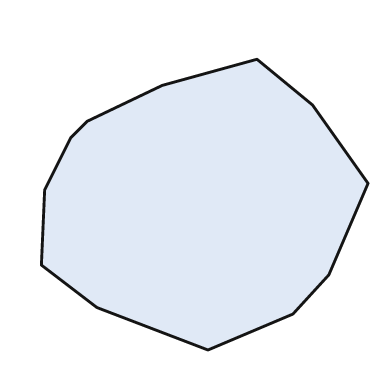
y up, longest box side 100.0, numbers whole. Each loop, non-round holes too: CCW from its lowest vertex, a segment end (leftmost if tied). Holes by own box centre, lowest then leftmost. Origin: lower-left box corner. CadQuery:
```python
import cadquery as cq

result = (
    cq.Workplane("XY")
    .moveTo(51.0, 0.0)
    .lineTo(77.0, 11.0)
    .lineTo(88.0, 23.0)
    .lineTo(100.0, 51.0)
    .lineTo(83.0, 75.0)
    .lineTo(66.0, 89.0)
    .lineTo(37.0, 81.0)
    .lineTo(14.0, 70.0)
    .lineTo(9.0, 65.0)
    .lineTo(1.0, 49.0)
    .lineTo(0.0, 26.0)
    .lineTo(17.0, 13.0)
    .close()
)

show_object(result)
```